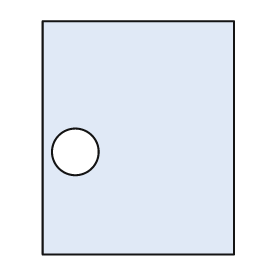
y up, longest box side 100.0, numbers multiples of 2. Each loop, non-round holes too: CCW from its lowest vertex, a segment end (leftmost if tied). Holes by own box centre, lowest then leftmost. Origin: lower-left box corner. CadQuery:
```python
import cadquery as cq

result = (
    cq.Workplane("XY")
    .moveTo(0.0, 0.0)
    .lineTo(82.0, 0.0)
    .lineTo(82.0, 100.0)
    .lineTo(0.0, 100.0)
    .close()
    .moveTo(14.0, 44.0)
    .circle(10.0)
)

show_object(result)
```